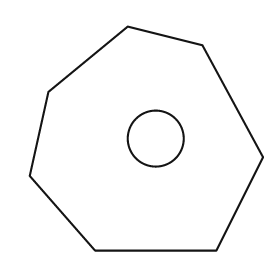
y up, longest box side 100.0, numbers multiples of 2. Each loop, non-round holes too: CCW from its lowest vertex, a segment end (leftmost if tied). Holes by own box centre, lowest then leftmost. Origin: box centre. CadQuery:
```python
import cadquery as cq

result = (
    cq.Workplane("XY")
    .moveTo(-22.0, -48.0)
    .lineTo(30.0, -48.0)
    .lineTo(50.0, -8.0)
    .lineTo(24.0, 40.0)
    .lineTo(-8.0, 48.0)
    .lineTo(-42.0, 20.0)
    .lineTo(-50.0, -16.0)
    .close()
    .moveTo(4.0, 0.0)
    .circle(12.0)
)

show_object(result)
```